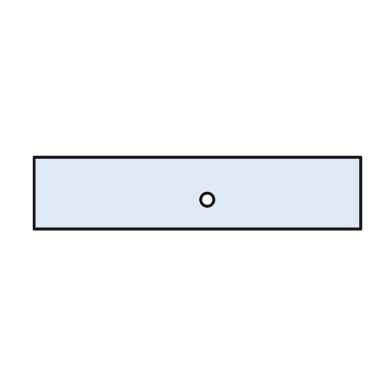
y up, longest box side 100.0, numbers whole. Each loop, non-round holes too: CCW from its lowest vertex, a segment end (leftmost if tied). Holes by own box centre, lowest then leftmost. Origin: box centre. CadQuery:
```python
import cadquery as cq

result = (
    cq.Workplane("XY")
    .moveTo(-50.0, -11.0)
    .lineTo(50.0, -11.0)
    .lineTo(50.0, 11.0)
    .lineTo(-50.0, 11.0)
    .close()
    .moveTo(3.0, -2.0)
    .circle(2.0)
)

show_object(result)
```